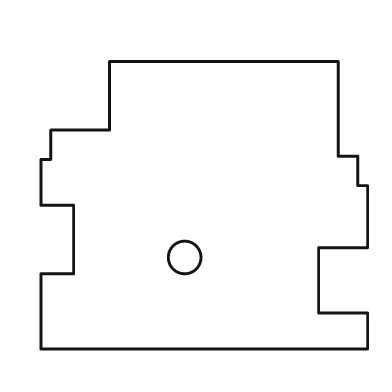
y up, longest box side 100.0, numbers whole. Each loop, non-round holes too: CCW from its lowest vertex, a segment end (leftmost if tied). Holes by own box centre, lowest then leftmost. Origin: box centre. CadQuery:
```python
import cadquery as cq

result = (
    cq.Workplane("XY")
    .moveTo(-50.0, -44.0)
    .lineTo(50.0, -44.0)
    .lineTo(50.0, -33.0)
    .lineTo(35.0, -33.0)
    .lineTo(35.0, -13.0)
    .lineTo(50.0, -13.0)
    .lineTo(50.0, 6.0)
    .lineTo(47.0, 6.0)
    .lineTo(47.0, 15.0)
    .lineTo(41.0, 15.0)
    .lineTo(41.0, 44.0)
    .lineTo(-29.0, 44.0)
    .lineTo(-29.0, 23.0)
    .lineTo(-47.0, 23.0)
    .lineTo(-47.0, 14.0)
    .lineTo(-50.0, 14.0)
    .lineTo(-50.0, 0.0)
    .lineTo(-40.0, 0.0)
    .lineTo(-40.0, -21.0)
    .lineTo(-50.0, -21.0)
    .close()
    .moveTo(-6.0, -16.0)
    .circle(5.0)
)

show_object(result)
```